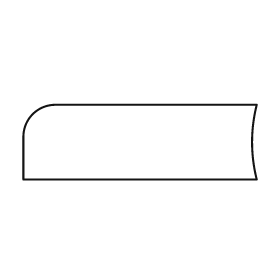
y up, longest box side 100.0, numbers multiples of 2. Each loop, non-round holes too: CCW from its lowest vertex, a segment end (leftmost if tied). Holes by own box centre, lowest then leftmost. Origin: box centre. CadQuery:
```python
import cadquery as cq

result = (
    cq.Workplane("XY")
    .moveTo(-50.0, -16.0)
    .lineTo(50.0, -16.0)
    .threePointArc((48.0, 0.0), (50.0, 16.0))
    .lineTo(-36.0, 16.0)
    .threePointArc((-46.0, 12.0), (-50.0, 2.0))
    .close()
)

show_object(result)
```